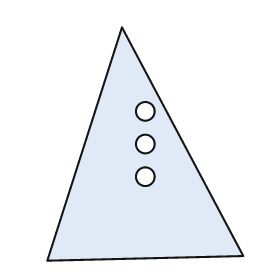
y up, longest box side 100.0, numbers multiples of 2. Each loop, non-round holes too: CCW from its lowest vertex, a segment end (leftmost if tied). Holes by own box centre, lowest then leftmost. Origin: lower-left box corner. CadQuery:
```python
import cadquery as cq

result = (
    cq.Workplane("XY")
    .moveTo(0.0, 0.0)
    .lineTo(84.0, 2.0)
    .lineTo(32.0, 100.0)
    .close()
    .moveTo(42.0, 36.0)
    .circle(4.0)
    .moveTo(42.0, 50.0)
    .circle(4.0)
    .moveTo(42.0, 64.0)
    .circle(4.0)
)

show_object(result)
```